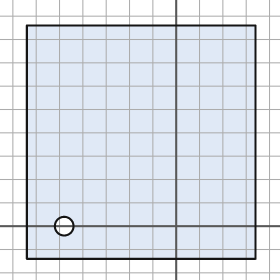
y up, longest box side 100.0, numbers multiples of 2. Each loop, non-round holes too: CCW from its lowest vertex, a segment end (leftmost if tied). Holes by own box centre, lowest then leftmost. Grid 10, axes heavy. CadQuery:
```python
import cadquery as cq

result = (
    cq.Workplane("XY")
    .moveTo(-64.0, -14.0)
    .lineTo(34.0, -14.0)
    .lineTo(34.0, 86.0)
    .lineTo(-64.0, 86.0)
    .close()
    .moveTo(-48.0, 0.0)
    .circle(4.0)
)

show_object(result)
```